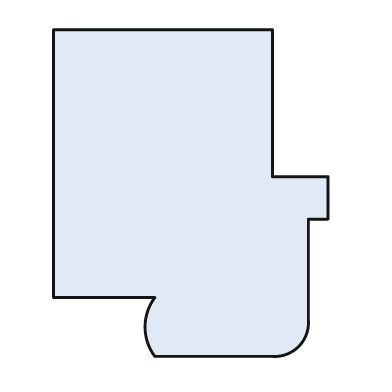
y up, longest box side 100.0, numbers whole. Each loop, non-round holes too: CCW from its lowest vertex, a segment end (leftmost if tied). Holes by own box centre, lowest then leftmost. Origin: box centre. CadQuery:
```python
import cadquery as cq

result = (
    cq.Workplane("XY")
    .moveTo(-11.0, -50.0)
    .lineTo(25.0, -50.0)
    .threePointArc((33.0, -47.0), (36.0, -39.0))
    .lineTo(36.0, -8.0)
    .lineTo(42.0, -8.0)
    .lineTo(42.0, 5.0)
    .lineTo(25.0, 5.0)
    .lineTo(25.0, 50.0)
    .lineTo(-42.0, 50.0)
    .lineTo(-42.0, -32.0)
    .lineTo(-11.0, -32.0)
    .threePointArc((-14.0, -41.0), (-11.0, -50.0))
    .close()
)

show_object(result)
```